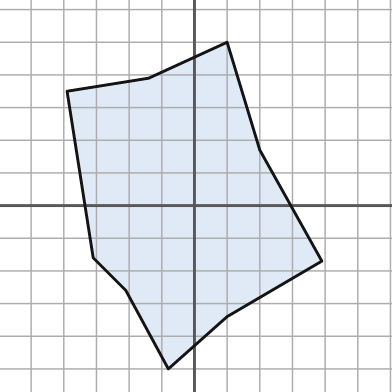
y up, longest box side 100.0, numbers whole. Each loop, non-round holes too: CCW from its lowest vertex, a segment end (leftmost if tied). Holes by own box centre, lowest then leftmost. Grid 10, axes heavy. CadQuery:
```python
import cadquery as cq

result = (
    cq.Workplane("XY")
    .moveTo(-8.0, -50.0)
    .lineTo(10.0, -34.0)
    .lineTo(39.0, -17.0)
    .lineTo(20.0, 17.0)
    .lineTo(10.0, 50.0)
    .lineTo(-14.0, 39.0)
    .lineTo(-39.0, 35.0)
    .lineTo(-31.0, -16.0)
    .lineTo(-21.0, -26.0)
    .close()
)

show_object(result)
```